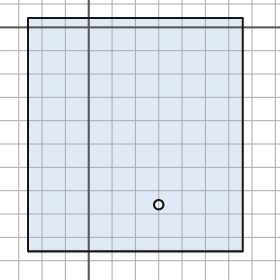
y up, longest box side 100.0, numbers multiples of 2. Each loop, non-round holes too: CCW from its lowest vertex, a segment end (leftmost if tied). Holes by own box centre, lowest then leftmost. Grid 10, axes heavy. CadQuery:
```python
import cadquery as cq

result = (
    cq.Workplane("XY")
    .moveTo(-26.0, -96.0)
    .lineTo(66.0, -96.0)
    .lineTo(66.0, 4.0)
    .lineTo(-26.0, 4.0)
    .close()
    .moveTo(30.0, -76.0)
    .circle(2.0)
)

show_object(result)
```